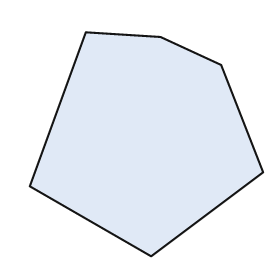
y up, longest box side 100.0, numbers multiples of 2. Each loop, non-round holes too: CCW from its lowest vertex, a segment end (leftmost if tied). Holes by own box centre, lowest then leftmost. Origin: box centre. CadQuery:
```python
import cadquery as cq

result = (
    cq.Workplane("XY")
    .moveTo(2.0, -48.0)
    .lineTo(50.0, -12.0)
    .lineTo(32.0, 34.0)
    .lineTo(6.0, 46.0)
    .lineTo(-26.0, 48.0)
    .lineTo(-50.0, -18.0)
    .close()
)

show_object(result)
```